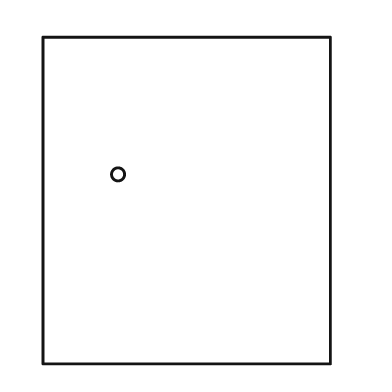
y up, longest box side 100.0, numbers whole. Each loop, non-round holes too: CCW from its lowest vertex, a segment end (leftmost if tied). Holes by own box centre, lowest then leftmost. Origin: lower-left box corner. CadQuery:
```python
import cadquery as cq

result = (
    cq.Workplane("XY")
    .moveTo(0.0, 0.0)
    .lineTo(88.0, 0.0)
    .lineTo(88.0, 100.0)
    .lineTo(0.0, 100.0)
    .close()
    .moveTo(23.0, 58.0)
    .circle(2.0)
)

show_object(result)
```